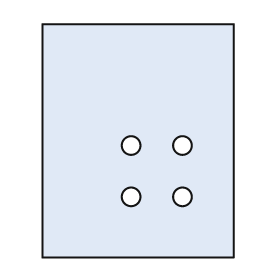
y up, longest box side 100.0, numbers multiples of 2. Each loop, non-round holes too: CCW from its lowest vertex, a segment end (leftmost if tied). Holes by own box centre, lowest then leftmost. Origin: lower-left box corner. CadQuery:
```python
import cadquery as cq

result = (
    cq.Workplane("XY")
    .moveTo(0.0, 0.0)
    .lineTo(82.0, 0.0)
    .lineTo(82.0, 100.0)
    .lineTo(0.0, 100.0)
    .close()
    .moveTo(38.0, 26.0)
    .circle(4.0)
    .moveTo(60.0, 26.0)
    .circle(4.0)
    .moveTo(38.0, 48.0)
    .circle(4.0)
    .moveTo(60.0, 48.0)
    .circle(4.0)
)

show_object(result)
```